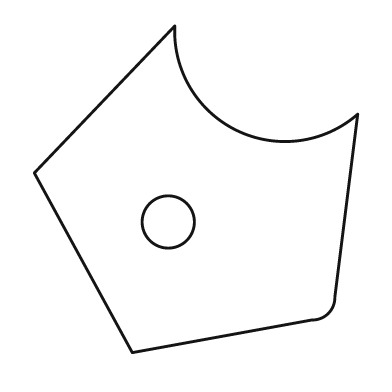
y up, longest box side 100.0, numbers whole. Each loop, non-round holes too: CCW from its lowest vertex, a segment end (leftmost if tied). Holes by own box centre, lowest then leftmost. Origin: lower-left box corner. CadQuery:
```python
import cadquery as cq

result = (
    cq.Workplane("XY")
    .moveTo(30.0, 0.0)
    .lineTo(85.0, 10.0)
    .threePointArc((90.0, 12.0), (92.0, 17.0))
    .lineTo(99.0, 73.0)
    .threePointArc((62.0, 68.0), (43.0, 100.0))
    .lineTo(0.0, 55.0)
    .close()
    .moveTo(41.0, 40.0)
    .circle(8.0)
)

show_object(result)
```